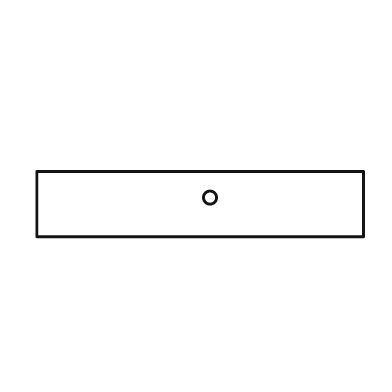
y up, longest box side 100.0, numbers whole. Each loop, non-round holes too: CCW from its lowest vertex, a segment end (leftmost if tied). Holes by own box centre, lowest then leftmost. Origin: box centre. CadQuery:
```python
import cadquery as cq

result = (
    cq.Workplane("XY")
    .moveTo(-50.0, -10.0)
    .lineTo(50.0, -10.0)
    .lineTo(50.0, 10.0)
    .lineTo(-50.0, 10.0)
    .close()
    .moveTo(3.0, 2.0)
    .circle(2.0)
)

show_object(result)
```